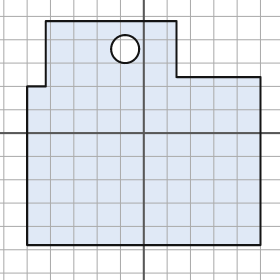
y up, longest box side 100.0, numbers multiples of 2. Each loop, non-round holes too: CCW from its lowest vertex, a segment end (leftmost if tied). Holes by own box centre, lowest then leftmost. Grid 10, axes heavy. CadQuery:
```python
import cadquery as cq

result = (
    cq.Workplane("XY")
    .moveTo(-50.0, -48.0)
    .lineTo(50.0, -48.0)
    .lineTo(50.0, 24.0)
    .lineTo(14.0, 24.0)
    .lineTo(14.0, 48.0)
    .lineTo(-42.0, 48.0)
    .lineTo(-42.0, 20.0)
    .lineTo(-50.0, 20.0)
    .close()
    .moveTo(-8.0, 36.0)
    .circle(6.0)
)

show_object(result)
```